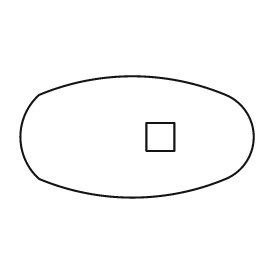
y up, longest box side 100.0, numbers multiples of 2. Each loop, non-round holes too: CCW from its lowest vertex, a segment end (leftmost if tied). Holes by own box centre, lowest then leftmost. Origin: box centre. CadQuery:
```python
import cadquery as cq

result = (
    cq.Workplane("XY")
    .moveTo(-42.0, -18.0)
    .threePointArc((-2.0, -26.0), (38.0, -18.0))
    .threePointArc((50.0, 0.0), (38.0, 18.0))
    .threePointArc((-2.0, 26.0), (-42.0, 18.0))
    .threePointArc((-50.0, 0.0), (-42.0, -18.0))
    .close()
    .moveTo(4.0, -6.0)
    .lineTo(16.0, -6.0)
    .lineTo(16.0, 6.0)
    .lineTo(4.0, 6.0)
    .close()
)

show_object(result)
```